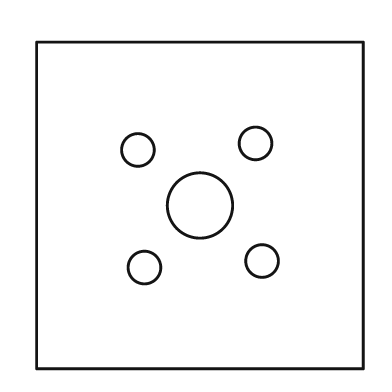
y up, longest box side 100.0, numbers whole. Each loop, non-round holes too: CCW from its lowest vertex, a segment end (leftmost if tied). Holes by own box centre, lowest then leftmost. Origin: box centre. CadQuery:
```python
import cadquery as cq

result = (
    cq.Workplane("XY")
    .moveTo(-50.0, -50.0)
    .lineTo(50.0, -50.0)
    .lineTo(50.0, 50.0)
    .lineTo(-50.0, 50.0)
    .close()
    .moveTo(-17.0, -19.0)
    .circle(5.0)
    .moveTo(19.0, -17.0)
    .circle(5.0)
    .moveTo(0.0, 0.0)
    .circle(10.0)
    .moveTo(-19.0, 17.0)
    .circle(5.0)
    .moveTo(17.0, 19.0)
    .circle(5.0)
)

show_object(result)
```